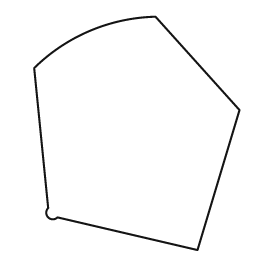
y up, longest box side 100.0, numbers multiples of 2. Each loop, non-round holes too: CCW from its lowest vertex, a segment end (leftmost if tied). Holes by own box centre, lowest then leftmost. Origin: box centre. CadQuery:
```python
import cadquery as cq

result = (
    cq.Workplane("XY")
    .moveTo(26.0, -50.0)
    .lineTo(44.0, 10.0)
    .lineTo(8.0, 50.0)
    .threePointArc((-20.0, 44.0), (-44.0, 28.0))
    .lineTo(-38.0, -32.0)
    .threePointArc((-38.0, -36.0), (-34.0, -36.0))
    .close()
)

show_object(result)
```